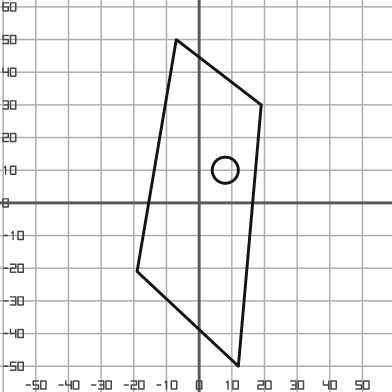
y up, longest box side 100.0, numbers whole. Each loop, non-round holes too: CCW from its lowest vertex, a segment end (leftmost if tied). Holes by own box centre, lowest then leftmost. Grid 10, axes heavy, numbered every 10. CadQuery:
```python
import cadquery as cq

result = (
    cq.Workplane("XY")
    .moveTo(12.0, -50.0)
    .lineTo(19.0, 30.0)
    .lineTo(-7.0, 50.0)
    .lineTo(-19.0, -21.0)
    .close()
    .moveTo(8.0, 10.0)
    .circle(4.0)
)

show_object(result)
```